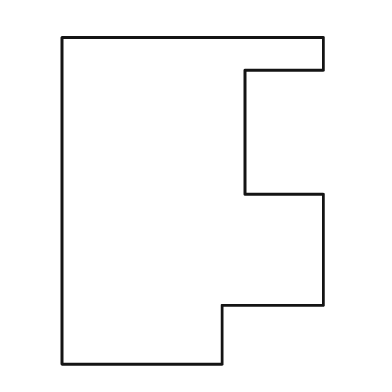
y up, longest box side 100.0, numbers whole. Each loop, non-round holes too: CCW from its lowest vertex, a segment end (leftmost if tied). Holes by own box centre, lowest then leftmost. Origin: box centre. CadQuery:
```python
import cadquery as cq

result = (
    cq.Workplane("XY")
    .moveTo(-40.0, -50.0)
    .lineTo(9.0, -50.0)
    .lineTo(9.0, -32.0)
    .lineTo(40.0, -32.0)
    .lineTo(40.0, 2.0)
    .lineTo(16.0, 2.0)
    .lineTo(16.0, 40.0)
    .lineTo(40.0, 40.0)
    .lineTo(40.0, 50.0)
    .lineTo(-40.0, 50.0)
    .close()
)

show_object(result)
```